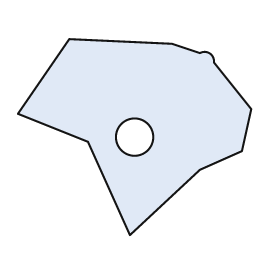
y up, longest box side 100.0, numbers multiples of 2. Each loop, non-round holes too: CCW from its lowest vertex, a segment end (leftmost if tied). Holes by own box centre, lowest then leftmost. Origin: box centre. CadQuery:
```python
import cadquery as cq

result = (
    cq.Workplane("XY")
    .moveTo(-2.0, -42.0)
    .lineTo(28.0, -14.0)
    .lineTo(46.0, -6.0)
    .lineTo(50.0, 12.0)
    .lineTo(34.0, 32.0)
    .threePointArc((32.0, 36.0), (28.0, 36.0))
    .lineTo(16.0, 40.0)
    .lineTo(-28.0, 42.0)
    .lineTo(-50.0, 10.0)
    .lineTo(-20.0, -2.0)
    .close()
    .moveTo(0.0, 0.0)
    .circle(8.0)
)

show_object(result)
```